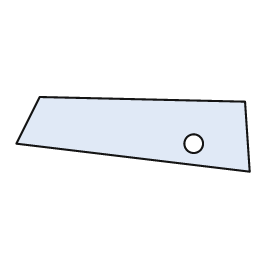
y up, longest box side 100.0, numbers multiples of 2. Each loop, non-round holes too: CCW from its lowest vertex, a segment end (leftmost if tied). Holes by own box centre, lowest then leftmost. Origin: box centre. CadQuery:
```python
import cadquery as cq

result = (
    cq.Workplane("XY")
    .moveTo(50.0, -16.0)
    .lineTo(48.0, 14.0)
    .lineTo(-40.0, 16.0)
    .lineTo(-50.0, -4.0)
    .close()
    .moveTo(26.0, -4.0)
    .circle(4.0)
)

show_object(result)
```